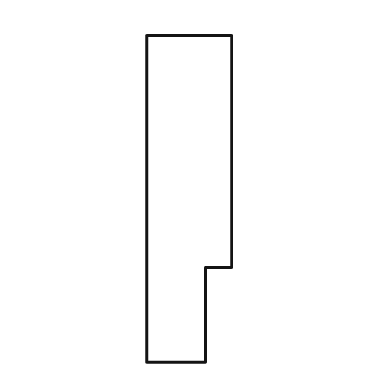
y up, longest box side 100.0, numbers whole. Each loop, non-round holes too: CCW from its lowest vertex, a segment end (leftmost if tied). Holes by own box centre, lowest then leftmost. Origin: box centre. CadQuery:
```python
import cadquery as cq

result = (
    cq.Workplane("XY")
    .moveTo(-13.0, -50.0)
    .lineTo(5.0, -50.0)
    .lineTo(5.0, -21.0)
    .lineTo(13.0, -21.0)
    .lineTo(13.0, 50.0)
    .lineTo(-13.0, 50.0)
    .close()
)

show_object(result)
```